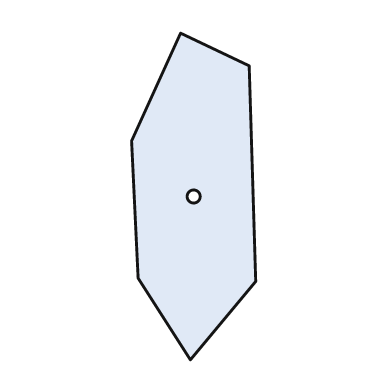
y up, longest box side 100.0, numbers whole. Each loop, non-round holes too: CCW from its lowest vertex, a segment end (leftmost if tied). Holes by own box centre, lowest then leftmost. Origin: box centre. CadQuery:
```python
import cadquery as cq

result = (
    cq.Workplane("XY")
    .moveTo(-1.0, -50.0)
    .lineTo(19.0, -26.0)
    .lineTo(17.0, 40.0)
    .lineTo(-4.0, 50.0)
    .lineTo(-19.0, 17.0)
    .lineTo(-17.0, -25.0)
    .close()
    .moveTo(0.0, 0.0)
    .circle(2.0)
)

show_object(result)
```